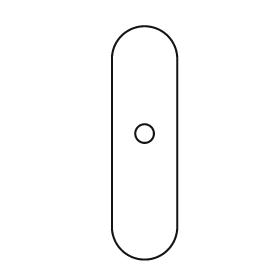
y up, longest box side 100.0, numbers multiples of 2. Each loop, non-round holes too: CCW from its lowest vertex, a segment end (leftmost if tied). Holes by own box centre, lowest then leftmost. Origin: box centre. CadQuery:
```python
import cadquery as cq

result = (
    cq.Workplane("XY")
    .moveTo(-14.0, -36.0)
    .threePointArc((0.0, -50.0), (14.0, -36.0))
    .lineTo(14.0, 36.0)
    .threePointArc((0.0, 50.0), (-14.0, 36.0))
    .close()
    .moveTo(0.0, 4.0)
    .circle(4.0)
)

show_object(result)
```